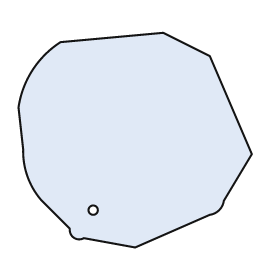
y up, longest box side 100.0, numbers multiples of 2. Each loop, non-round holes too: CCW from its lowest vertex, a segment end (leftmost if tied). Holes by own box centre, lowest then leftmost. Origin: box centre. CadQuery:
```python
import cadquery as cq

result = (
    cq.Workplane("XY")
    .moveTo(0.0, -46.0)
    .lineTo(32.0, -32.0)
    .threePointArc((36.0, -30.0), (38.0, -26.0))
    .lineTo(50.0, -6.0)
    .lineTo(32.0, 36.0)
    .lineTo(12.0, 46.0)
    .lineTo(-32.0, 42.0)
    .threePointArc((-44.0, 30.0), (-50.0, 14.0))
    .lineTo(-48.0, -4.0)
    .threePointArc((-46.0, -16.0), (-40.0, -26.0))
    .lineTo(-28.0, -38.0)
    .threePointArc((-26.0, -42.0), (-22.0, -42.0))
    .close()
    .moveTo(-18.0, -30.0)
    .circle(2.0)
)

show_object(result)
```